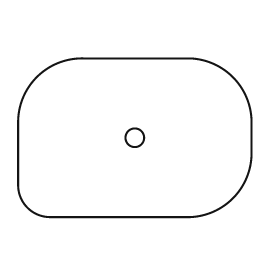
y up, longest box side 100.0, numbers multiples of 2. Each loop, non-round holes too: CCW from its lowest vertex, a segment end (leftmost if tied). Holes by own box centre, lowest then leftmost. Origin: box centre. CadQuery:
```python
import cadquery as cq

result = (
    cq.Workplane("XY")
    .moveTo(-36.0, -34.0)
    .lineTo(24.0, -34.0)
    .threePointArc((42.0, -26.0), (50.0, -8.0))
    .lineTo(50.0, 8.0)
    .threePointArc((42.0, 26.0), (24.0, 34.0))
    .lineTo(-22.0, 34.0)
    .threePointArc((-42.0, 26.0), (-50.0, 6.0))
    .lineTo(-50.0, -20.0)
    .threePointArc((-46.0, -30.0), (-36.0, -34.0))
    .close()
    .moveTo(0.0, 0.0)
    .circle(4.0)
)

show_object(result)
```